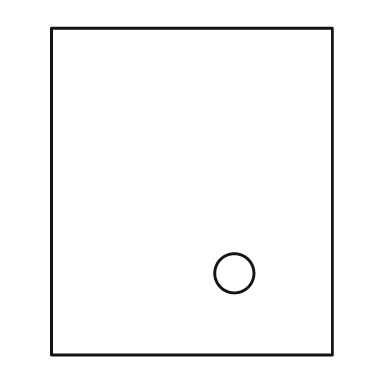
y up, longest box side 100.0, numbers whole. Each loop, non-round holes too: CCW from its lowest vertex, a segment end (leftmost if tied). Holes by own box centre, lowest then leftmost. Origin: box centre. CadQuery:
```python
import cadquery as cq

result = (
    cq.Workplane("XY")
    .moveTo(-43.0, -50.0)
    .lineTo(43.0, -50.0)
    .lineTo(43.0, 50.0)
    .lineTo(-43.0, 50.0)
    .close()
    .moveTo(13.0, -25.0)
    .circle(6.0)
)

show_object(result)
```